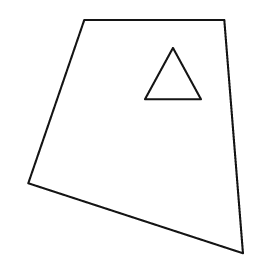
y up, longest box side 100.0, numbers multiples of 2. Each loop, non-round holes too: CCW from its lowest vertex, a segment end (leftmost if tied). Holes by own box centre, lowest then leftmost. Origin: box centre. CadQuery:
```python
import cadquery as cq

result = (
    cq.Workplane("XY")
    .moveTo(46.0, -50.0)
    .lineTo(38.0, 50.0)
    .lineTo(-22.0, 50.0)
    .lineTo(-46.0, -20.0)
    .close()
    .moveTo(4.0, 16.0)
    .lineTo(28.0, 16.0)
    .lineTo(16.0, 38.0)
    .close()
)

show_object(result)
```